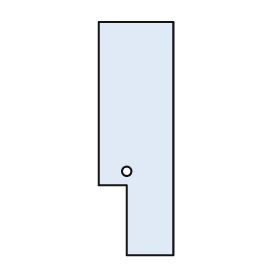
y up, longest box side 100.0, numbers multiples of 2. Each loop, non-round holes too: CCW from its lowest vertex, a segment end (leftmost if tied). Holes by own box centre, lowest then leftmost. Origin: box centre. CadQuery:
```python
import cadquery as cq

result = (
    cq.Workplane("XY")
    .moveTo(-4.0, -50.0)
    .lineTo(16.0, -50.0)
    .lineTo(16.0, 50.0)
    .lineTo(-16.0, 50.0)
    .lineTo(-16.0, -20.0)
    .lineTo(-4.0, -20.0)
    .close()
    .moveTo(-4.0, -14.0)
    .circle(2.0)
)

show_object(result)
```